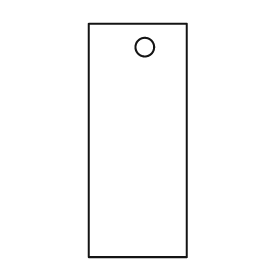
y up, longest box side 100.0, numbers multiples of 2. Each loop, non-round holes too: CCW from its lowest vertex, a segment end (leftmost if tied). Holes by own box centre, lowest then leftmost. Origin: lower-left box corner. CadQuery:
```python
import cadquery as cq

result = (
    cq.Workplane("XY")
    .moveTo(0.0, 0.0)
    .lineTo(42.0, 0.0)
    .lineTo(42.0, 100.0)
    .lineTo(0.0, 100.0)
    .close()
    .moveTo(24.0, 90.0)
    .circle(4.0)
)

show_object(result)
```